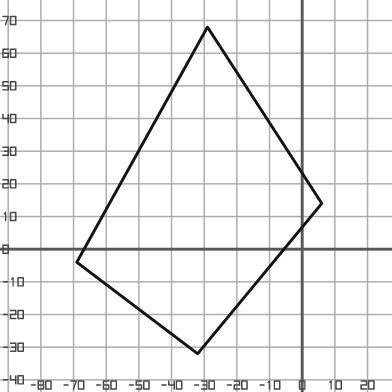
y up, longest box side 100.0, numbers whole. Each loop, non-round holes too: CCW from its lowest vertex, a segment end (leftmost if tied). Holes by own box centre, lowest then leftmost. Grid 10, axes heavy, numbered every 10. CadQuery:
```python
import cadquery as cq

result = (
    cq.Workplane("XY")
    .moveTo(-32.0, -32.0)
    .lineTo(6.0, 14.0)
    .lineTo(-29.0, 68.0)
    .lineTo(-69.0, -4.0)
    .close()
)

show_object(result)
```